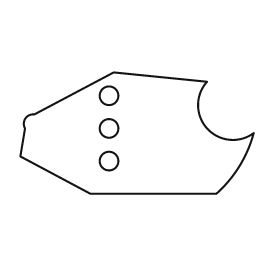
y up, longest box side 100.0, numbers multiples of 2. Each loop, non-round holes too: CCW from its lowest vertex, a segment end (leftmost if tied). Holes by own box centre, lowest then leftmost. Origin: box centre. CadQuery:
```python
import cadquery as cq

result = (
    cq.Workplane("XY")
    .moveTo(-20.0, -26.0)
    .lineTo(34.0, -26.0)
    .threePointArc((44.0, -14.0), (50.0, 0.0))
    .threePointArc((30.0, 2.0), (30.0, 22.0))
    .lineTo(-10.0, 26.0)
    .lineTo(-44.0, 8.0)
    .threePointArc((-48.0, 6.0), (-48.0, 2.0))
    .lineTo(-50.0, -10.0)
    .close()
    .moveTo(-12.0, -12.0)
    .circle(4.0)
    .moveTo(-12.0, 2.0)
    .circle(4.0)
    .moveTo(-12.0, 16.0)
    .circle(4.0)
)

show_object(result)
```